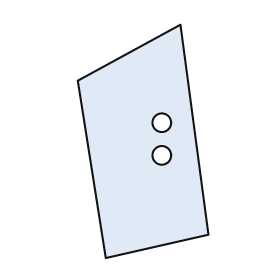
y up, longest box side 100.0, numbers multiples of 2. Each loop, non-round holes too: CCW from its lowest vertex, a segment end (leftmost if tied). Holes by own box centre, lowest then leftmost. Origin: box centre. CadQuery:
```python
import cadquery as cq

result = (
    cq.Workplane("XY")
    .moveTo(-16.0, -50.0)
    .lineTo(28.0, -40.0)
    .lineTo(16.0, 50.0)
    .lineTo(-28.0, 26.0)
    .close()
    .moveTo(8.0, -6.0)
    .circle(4.0)
    .moveTo(8.0, 8.0)
    .circle(4.0)
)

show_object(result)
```